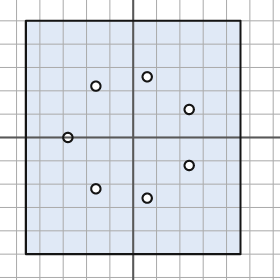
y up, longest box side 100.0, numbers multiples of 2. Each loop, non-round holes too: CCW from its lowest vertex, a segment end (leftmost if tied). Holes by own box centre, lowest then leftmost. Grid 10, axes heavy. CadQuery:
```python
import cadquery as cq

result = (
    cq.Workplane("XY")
    .moveTo(-46.0, -50.0)
    .lineTo(46.0, -50.0)
    .lineTo(46.0, 50.0)
    .lineTo(-46.0, 50.0)
    .close()
    .moveTo(6.0, -26.0)
    .circle(2.0)
    .moveTo(-16.0, -22.0)
    .circle(2.0)
    .moveTo(24.0, -12.0)
    .circle(2.0)
    .moveTo(-28.0, 0.0)
    .circle(2.0)
    .moveTo(24.0, 12.0)
    .circle(2.0)
    .moveTo(-16.0, 22.0)
    .circle(2.0)
    .moveTo(6.0, 26.0)
    .circle(2.0)
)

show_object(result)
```